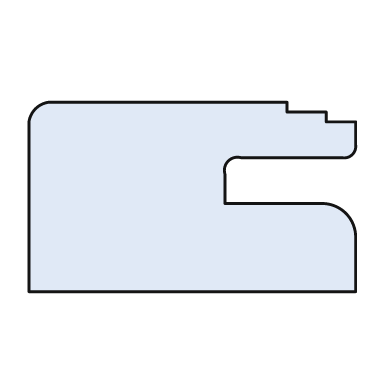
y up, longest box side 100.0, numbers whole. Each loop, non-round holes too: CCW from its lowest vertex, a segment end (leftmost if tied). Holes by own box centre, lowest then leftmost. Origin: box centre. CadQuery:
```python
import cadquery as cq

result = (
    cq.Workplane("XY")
    .moveTo(-50.0, -29.0)
    .lineTo(50.0, -29.0)
    .lineTo(50.0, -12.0)
    .threePointArc((47.0, -5.0), (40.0, -2.0))
    .lineTo(10.0, -2.0)
    .lineTo(10.0, 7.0)
    .threePointArc((11.0, 11.0), (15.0, 12.0))
    .lineTo(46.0, 12.0)
    .threePointArc((49.0, 13.0), (50.0, 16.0))
    .lineTo(50.0, 23.0)
    .lineTo(41.0, 23.0)
    .lineTo(41.0, 26.0)
    .lineTo(29.0, 26.0)
    .lineTo(29.0, 29.0)
    .lineTo(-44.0, 29.0)
    .threePointArc((-48.0, 27.0), (-50.0, 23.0))
    .close()
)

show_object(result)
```